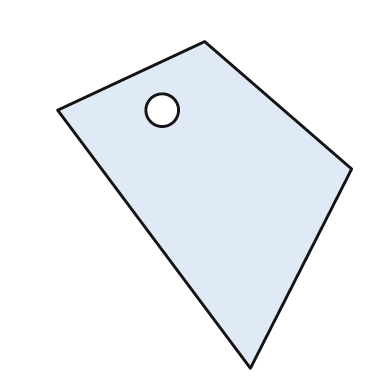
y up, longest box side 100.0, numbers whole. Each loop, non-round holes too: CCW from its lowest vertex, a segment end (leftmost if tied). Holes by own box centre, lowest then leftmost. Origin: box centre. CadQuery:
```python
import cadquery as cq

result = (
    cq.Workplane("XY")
    .moveTo(14.0, -50.0)
    .lineTo(45.0, 11.0)
    .lineTo(0.0, 50.0)
    .lineTo(-45.0, 29.0)
    .close()
    .moveTo(-13.0, 29.0)
    .circle(5.0)
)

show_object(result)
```